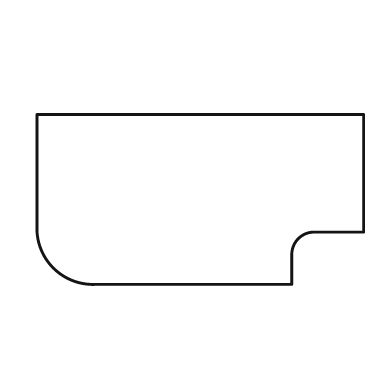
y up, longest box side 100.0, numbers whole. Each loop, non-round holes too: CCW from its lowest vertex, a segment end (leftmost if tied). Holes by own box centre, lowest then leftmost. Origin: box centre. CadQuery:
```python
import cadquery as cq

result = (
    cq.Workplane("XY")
    .moveTo(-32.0, -26.0)
    .lineTo(28.0, -26.0)
    .lineTo(28.0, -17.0)
    .threePointArc((30.0, -12.0), (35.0, -10.0))
    .lineTo(50.0, -10.0)
    .lineTo(50.0, 26.0)
    .lineTo(-50.0, 26.0)
    .lineTo(-50.0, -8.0)
    .threePointArc((-45.0, -21.0), (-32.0, -26.0))
    .close()
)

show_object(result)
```